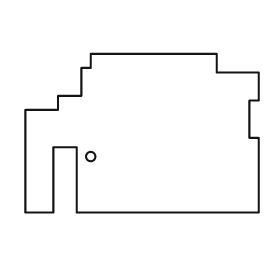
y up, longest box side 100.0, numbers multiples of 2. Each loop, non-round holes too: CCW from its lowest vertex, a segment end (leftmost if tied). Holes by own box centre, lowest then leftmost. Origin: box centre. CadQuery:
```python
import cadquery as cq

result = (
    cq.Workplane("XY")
    .moveTo(-50.0, -34.0)
    .lineTo(-38.0, -34.0)
    .lineTo(-38.0, -6.0)
    .lineTo(-28.0, -6.0)
    .lineTo(-28.0, -34.0)
    .lineTo(50.0, -34.0)
    .lineTo(50.0, -2.0)
    .lineTo(46.0, -2.0)
    .lineTo(46.0, 14.0)
    .lineTo(50.0, 14.0)
    .lineTo(50.0, 26.0)
    .lineTo(32.0, 26.0)
    .lineTo(32.0, 34.0)
    .lineTo(-22.0, 34.0)
    .lineTo(-22.0, 28.0)
    .lineTo(-26.0, 28.0)
    .lineTo(-26.0, 16.0)
    .lineTo(-36.0, 16.0)
    .lineTo(-36.0, 10.0)
    .lineTo(-50.0, 10.0)
    .close()
    .moveTo(-22.0, -10.0)
    .circle(2.0)
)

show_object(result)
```